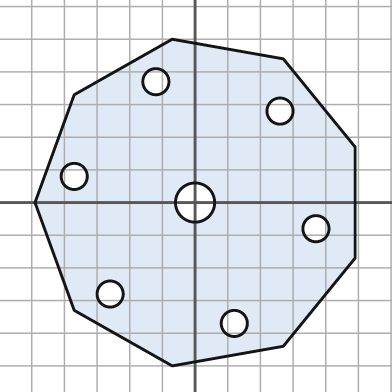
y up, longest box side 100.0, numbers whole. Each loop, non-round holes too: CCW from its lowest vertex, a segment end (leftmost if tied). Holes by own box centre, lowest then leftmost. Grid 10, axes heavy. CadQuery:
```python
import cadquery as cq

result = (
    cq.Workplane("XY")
    .moveTo(-7.0, -50.0)
    .lineTo(27.0, -44.0)
    .lineTo(49.0, -17.0)
    .lineTo(49.0, 17.0)
    .lineTo(27.0, 44.0)
    .lineTo(-7.0, 50.0)
    .lineTo(-37.0, 33.0)
    .lineTo(-49.0, 0.0)
    .lineTo(-37.0, -33.0)
    .close()
    .moveTo(12.0, -37.0)
    .circle(4.0)
    .moveTo(-26.0, -28.0)
    .circle(4.0)
    .moveTo(37.0, -8.0)
    .circle(4.0)
    .moveTo(0.0, 0.0)
    .circle(6.0)
    .moveTo(-37.0, 8.0)
    .circle(4.0)
    .moveTo(26.0, 28.0)
    .circle(4.0)
    .moveTo(-12.0, 37.0)
    .circle(4.0)
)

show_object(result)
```